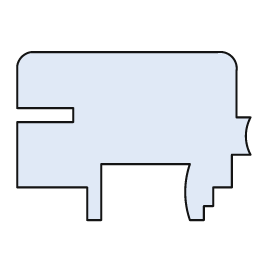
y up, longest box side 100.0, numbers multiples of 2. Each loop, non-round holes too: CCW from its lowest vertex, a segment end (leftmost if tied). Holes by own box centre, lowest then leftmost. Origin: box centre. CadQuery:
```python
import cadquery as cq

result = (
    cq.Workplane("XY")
    .moveTo(-20.0, -36.0)
    .lineTo(-14.0, -36.0)
    .lineTo(-14.0, -12.0)
    .lineTo(24.0, -12.0)
    .threePointArc((22.0, -24.0), (24.0, -36.0))
    .lineTo(30.0, -36.0)
    .lineTo(30.0, -30.0)
    .lineTo(34.0, -30.0)
    .lineTo(34.0, -22.0)
    .lineTo(42.0, -22.0)
    .lineTo(42.0, -8.0)
    .lineTo(50.0, -8.0)
    .threePointArc((48.0, 0.0), (50.0, 8.0))
    .lineTo(44.0, 8.0)
    .lineTo(44.0, 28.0)
    .threePointArc((42.0, 34.0), (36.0, 36.0))
    .lineTo(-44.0, 36.0)
    .threePointArc((-48.0, 34.0), (-50.0, 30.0))
    .lineTo(-50.0, 12.0)
    .lineTo(-26.0, 12.0)
    .lineTo(-26.0, 6.0)
    .lineTo(-50.0, 6.0)
    .lineTo(-50.0, -22.0)
    .lineTo(-20.0, -22.0)
    .close()
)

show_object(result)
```